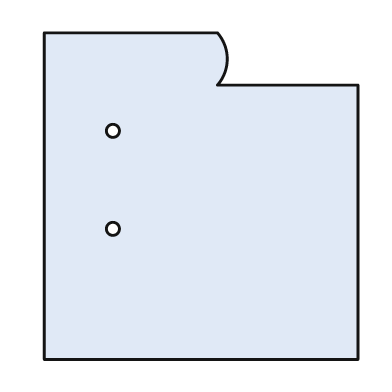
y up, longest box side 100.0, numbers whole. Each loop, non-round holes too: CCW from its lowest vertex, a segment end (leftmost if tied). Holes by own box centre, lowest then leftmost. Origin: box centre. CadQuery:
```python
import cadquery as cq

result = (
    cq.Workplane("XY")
    .moveTo(-48.0, -50.0)
    .lineTo(48.0, -50.0)
    .lineTo(48.0, 34.0)
    .lineTo(5.0, 34.0)
    .threePointArc((8.0, 42.0), (5.0, 50.0))
    .lineTo(-48.0, 50.0)
    .close()
    .moveTo(-27.0, -10.0)
    .circle(2.0)
    .moveTo(-27.0, 20.0)
    .circle(2.0)
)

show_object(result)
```